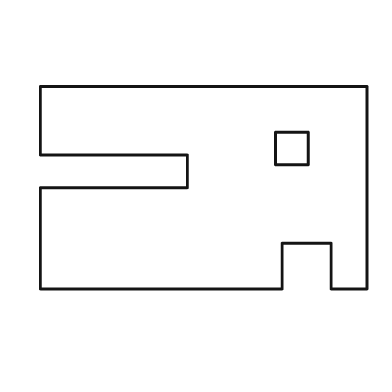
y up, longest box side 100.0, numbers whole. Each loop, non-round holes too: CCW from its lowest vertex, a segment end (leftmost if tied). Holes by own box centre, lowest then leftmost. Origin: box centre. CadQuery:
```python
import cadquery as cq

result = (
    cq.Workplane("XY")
    .moveTo(-50.0, -31.0)
    .lineTo(24.0, -31.0)
    .lineTo(24.0, -17.0)
    .lineTo(39.0, -17.0)
    .lineTo(39.0, -31.0)
    .lineTo(50.0, -31.0)
    .lineTo(50.0, 31.0)
    .lineTo(-50.0, 31.0)
    .lineTo(-50.0, 10.0)
    .lineTo(-5.0, 10.0)
    .lineTo(-5.0, 0.0)
    .lineTo(-50.0, 0.0)
    .close()
    .moveTo(22.0, 7.0)
    .lineTo(32.0, 7.0)
    .lineTo(32.0, 17.0)
    .lineTo(22.0, 17.0)
    .close()
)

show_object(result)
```